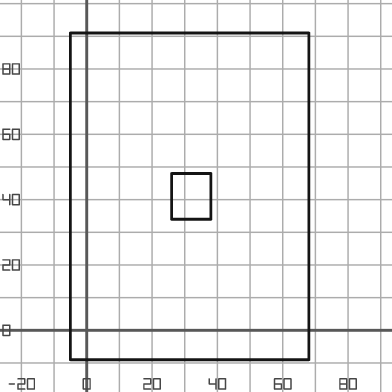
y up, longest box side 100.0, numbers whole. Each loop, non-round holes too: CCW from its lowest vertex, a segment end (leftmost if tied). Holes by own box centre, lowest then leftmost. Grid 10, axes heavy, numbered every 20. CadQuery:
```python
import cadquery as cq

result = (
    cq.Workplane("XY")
    .moveTo(-5.0, -9.0)
    .lineTo(68.0, -9.0)
    .lineTo(68.0, 91.0)
    .lineTo(-5.0, 91.0)
    .close()
    .moveTo(26.0, 34.0)
    .lineTo(38.0, 34.0)
    .lineTo(38.0, 48.0)
    .lineTo(26.0, 48.0)
    .close()
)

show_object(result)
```